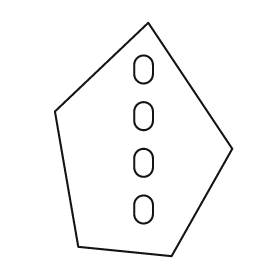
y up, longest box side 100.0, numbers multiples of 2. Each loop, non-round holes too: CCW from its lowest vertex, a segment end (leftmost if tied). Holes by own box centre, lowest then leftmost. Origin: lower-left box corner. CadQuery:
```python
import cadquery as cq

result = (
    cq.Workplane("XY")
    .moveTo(50.0, 0.0)
    .lineTo(76.0, 46.0)
    .lineTo(40.0, 100.0)
    .lineTo(0.0, 62.0)
    .lineTo(10.0, 4.0)
    .close()
    .moveTo(34.0, 18.0)
    .threePointArc((38.0, 14.0), (42.0, 18.0))
    .lineTo(42.0, 22.0)
    .threePointArc((38.0, 26.0), (34.0, 22.0))
    .close()
    .moveTo(34.0, 38.0)
    .threePointArc((38.0, 34.0), (42.0, 38.0))
    .lineTo(42.0, 42.0)
    .threePointArc((38.0, 46.0), (34.0, 42.0))
    .close()
    .moveTo(34.0, 58.0)
    .threePointArc((38.0, 54.0), (42.0, 58.0))
    .lineTo(42.0, 62.0)
    .threePointArc((38.0, 66.0), (34.0, 62.0))
    .close()
    .moveTo(34.0, 78.0)
    .threePointArc((38.0, 74.0), (42.0, 78.0))
    .lineTo(42.0, 82.0)
    .threePointArc((38.0, 86.0), (34.0, 82.0))
    .close()
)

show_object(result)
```